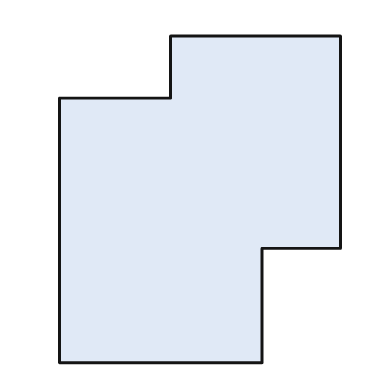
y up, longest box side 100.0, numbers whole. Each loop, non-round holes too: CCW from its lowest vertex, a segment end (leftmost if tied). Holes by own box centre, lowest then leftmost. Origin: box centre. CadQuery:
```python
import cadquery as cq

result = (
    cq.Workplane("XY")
    .moveTo(-43.0, -50.0)
    .lineTo(19.0, -50.0)
    .lineTo(19.0, -15.0)
    .lineTo(43.0, -15.0)
    .lineTo(43.0, 50.0)
    .lineTo(-9.0, 50.0)
    .lineTo(-9.0, 31.0)
    .lineTo(-43.0, 31.0)
    .close()
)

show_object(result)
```